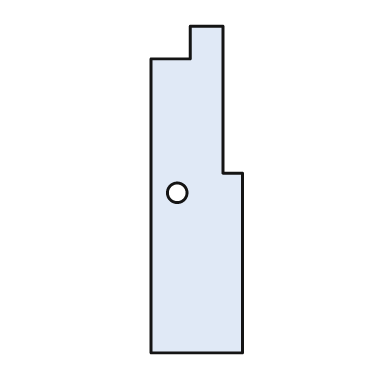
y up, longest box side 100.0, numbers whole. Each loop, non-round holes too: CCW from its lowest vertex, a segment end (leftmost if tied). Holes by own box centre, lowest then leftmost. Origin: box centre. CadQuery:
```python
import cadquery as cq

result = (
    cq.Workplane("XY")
    .moveTo(-14.0, -50.0)
    .lineTo(14.0, -50.0)
    .lineTo(14.0, 5.0)
    .lineTo(8.0, 5.0)
    .lineTo(8.0, 50.0)
    .lineTo(-2.0, 50.0)
    .lineTo(-2.0, 40.0)
    .lineTo(-14.0, 40.0)
    .close()
    .moveTo(-6.0, -1.0)
    .circle(3.0)
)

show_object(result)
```